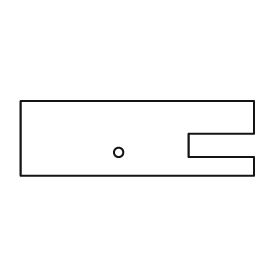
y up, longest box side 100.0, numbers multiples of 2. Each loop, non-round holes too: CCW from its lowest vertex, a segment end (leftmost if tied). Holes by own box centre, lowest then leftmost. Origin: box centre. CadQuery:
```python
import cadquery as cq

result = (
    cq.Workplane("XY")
    .moveTo(-50.0, -16.0)
    .lineTo(50.0, -16.0)
    .lineTo(50.0, -8.0)
    .lineTo(22.0, -8.0)
    .lineTo(22.0, 2.0)
    .lineTo(50.0, 2.0)
    .lineTo(50.0, 16.0)
    .lineTo(-50.0, 16.0)
    .close()
    .moveTo(-8.0, -6.0)
    .circle(2.0)
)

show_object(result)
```